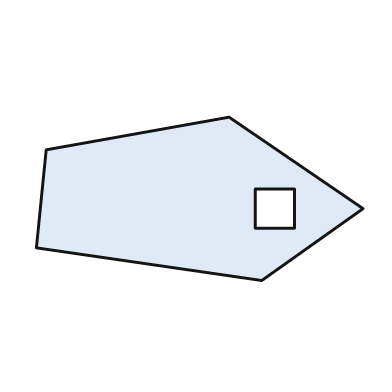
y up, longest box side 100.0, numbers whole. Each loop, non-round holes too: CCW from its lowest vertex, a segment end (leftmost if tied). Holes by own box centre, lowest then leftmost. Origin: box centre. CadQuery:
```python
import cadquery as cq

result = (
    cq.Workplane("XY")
    .moveTo(19.0, -25.0)
    .lineTo(50.0, -3.0)
    .lineTo(9.0, 25.0)
    .lineTo(-47.0, 15.0)
    .lineTo(-50.0, -15.0)
    .close()
    .moveTo(17.0, -9.0)
    .lineTo(29.0, -9.0)
    .lineTo(29.0, 3.0)
    .lineTo(17.0, 3.0)
    .close()
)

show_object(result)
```